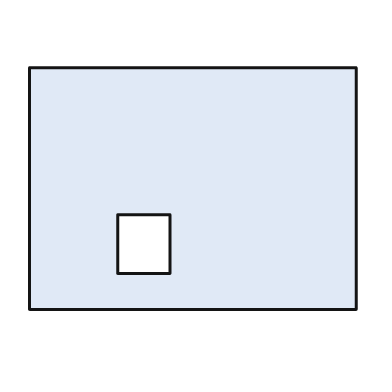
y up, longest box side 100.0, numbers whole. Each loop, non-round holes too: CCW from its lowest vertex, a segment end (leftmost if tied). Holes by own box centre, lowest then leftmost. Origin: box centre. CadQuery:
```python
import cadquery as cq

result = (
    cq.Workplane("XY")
    .moveTo(-50.0, -37.0)
    .lineTo(50.0, -37.0)
    .lineTo(50.0, 37.0)
    .lineTo(-50.0, 37.0)
    .close()
    .moveTo(-23.0, -26.0)
    .lineTo(-7.0, -26.0)
    .lineTo(-7.0, -8.0)
    .lineTo(-23.0, -8.0)
    .close()
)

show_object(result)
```